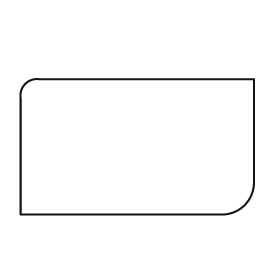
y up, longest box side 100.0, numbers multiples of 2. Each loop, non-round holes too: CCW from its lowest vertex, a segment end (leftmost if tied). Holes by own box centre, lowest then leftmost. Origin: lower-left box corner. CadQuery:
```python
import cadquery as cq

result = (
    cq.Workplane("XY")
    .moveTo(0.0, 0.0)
    .lineTo(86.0, 0.0)
    .threePointArc((96.0, 4.0), (100.0, 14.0))
    .lineTo(100.0, 58.0)
    .lineTo(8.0, 58.0)
    .threePointArc((2.0, 56.0), (0.0, 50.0))
    .close()
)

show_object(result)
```